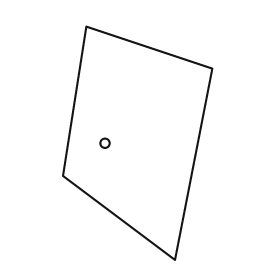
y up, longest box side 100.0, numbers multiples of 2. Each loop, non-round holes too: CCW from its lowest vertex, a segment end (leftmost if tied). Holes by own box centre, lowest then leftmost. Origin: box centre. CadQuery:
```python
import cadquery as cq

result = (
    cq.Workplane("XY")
    .moveTo(16.0, -50.0)
    .lineTo(32.0, 32.0)
    .lineTo(-22.0, 50.0)
    .lineTo(-32.0, -14.0)
    .close()
    .moveTo(-14.0, 0.0)
    .circle(2.0)
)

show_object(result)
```